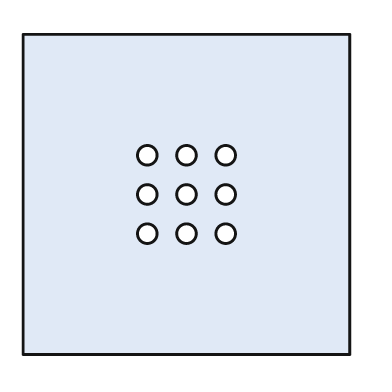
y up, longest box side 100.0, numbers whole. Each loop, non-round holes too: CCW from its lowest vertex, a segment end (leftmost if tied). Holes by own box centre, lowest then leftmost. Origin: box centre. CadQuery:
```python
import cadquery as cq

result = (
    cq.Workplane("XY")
    .moveTo(-50.0, -49.0)
    .lineTo(50.0, -49.0)
    .lineTo(50.0, 49.0)
    .lineTo(-50.0, 49.0)
    .close()
    .moveTo(-12.0, -12.0)
    .circle(3.0)
    .moveTo(0.0, -12.0)
    .circle(3.0)
    .moveTo(12.0, -12.0)
    .circle(3.0)
    .moveTo(-12.0, 0.0)
    .circle(3.0)
    .moveTo(0.0, 0.0)
    .circle(3.0)
    .moveTo(12.0, 0.0)
    .circle(3.0)
    .moveTo(-12.0, 12.0)
    .circle(3.0)
    .moveTo(0.0, 12.0)
    .circle(3.0)
    .moveTo(12.0, 12.0)
    .circle(3.0)
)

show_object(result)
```